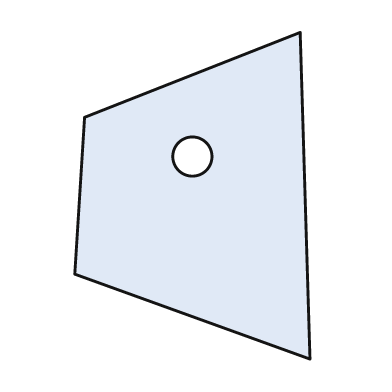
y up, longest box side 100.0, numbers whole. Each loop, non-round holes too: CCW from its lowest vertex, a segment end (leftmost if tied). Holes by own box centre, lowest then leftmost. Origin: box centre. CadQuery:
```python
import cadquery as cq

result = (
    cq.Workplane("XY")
    .moveTo(36.0, -50.0)
    .lineTo(33.0, 50.0)
    .lineTo(-33.0, 24.0)
    .lineTo(-36.0, -24.0)
    .close()
    .moveTo(0.0, 12.0)
    .circle(6.0)
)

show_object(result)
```